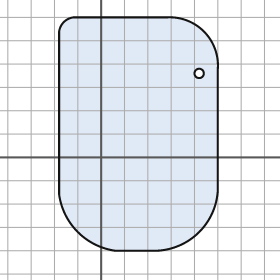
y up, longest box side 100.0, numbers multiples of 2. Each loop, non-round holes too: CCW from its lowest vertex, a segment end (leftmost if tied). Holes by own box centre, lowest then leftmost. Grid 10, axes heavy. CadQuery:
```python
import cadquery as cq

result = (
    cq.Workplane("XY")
    .moveTo(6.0, -40.0)
    .lineTo(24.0, -40.0)
    .threePointArc((42.0, -32.0), (50.0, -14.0))
    .lineTo(50.0, 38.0)
    .threePointArc((44.0, 54.0), (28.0, 60.0))
    .lineTo(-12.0, 60.0)
    .threePointArc((-16.0, 58.0), (-18.0, 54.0))
    .lineTo(-18.0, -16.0)
    .threePointArc((-10.0, -32.0), (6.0, -40.0))
    .close()
    .moveTo(42.0, 36.0)
    .circle(2.0)
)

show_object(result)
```